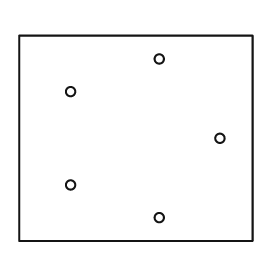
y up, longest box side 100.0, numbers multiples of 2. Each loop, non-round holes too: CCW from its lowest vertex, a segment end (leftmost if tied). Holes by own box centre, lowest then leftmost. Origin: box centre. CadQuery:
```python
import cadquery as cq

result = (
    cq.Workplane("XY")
    .moveTo(-50.0, -44.0)
    .lineTo(50.0, -44.0)
    .lineTo(50.0, 44.0)
    .lineTo(-50.0, 44.0)
    .close()
    .moveTo(10.0, -34.0)
    .circle(2.0)
    .moveTo(-28.0, -20.0)
    .circle(2.0)
    .moveTo(36.0, 0.0)
    .circle(2.0)
    .moveTo(-28.0, 20.0)
    .circle(2.0)
    .moveTo(10.0, 34.0)
    .circle(2.0)
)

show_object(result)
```